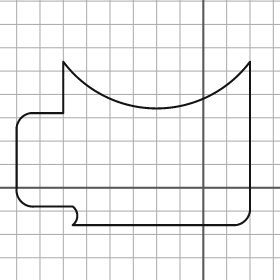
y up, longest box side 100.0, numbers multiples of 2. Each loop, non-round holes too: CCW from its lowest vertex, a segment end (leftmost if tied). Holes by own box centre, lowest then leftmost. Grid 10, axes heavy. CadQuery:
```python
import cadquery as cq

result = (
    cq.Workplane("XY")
    .moveTo(-56.0, -16.0)
    .lineTo(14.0, -16.0)
    .threePointArc((18.0, -14.0), (20.0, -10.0))
    .lineTo(20.0, 54.0)
    .threePointArc((-20.0, 34.0), (-60.0, 54.0))
    .lineTo(-60.0, 32.0)
    .lineTo(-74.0, 32.0)
    .threePointArc((-78.0, 30.0), (-80.0, 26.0))
    .lineTo(-80.0, 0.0)
    .threePointArc((-78.0, -6.0), (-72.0, -8.0))
    .lineTo(-56.0, -8.0)
    .threePointArc((-54.0, -12.0), (-56.0, -16.0))
    .close()
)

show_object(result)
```